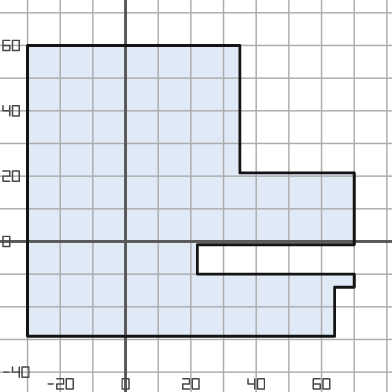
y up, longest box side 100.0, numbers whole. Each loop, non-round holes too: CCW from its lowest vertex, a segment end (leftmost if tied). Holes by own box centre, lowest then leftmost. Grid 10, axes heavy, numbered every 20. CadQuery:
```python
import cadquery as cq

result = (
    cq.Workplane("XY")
    .moveTo(-30.0, -29.0)
    .lineTo(64.0, -29.0)
    .lineTo(64.0, -14.0)
    .lineTo(70.0, -14.0)
    .lineTo(70.0, -10.0)
    .lineTo(22.0, -10.0)
    .lineTo(22.0, -1.0)
    .lineTo(70.0, -1.0)
    .lineTo(70.0, 21.0)
    .lineTo(35.0, 21.0)
    .lineTo(35.0, 60.0)
    .lineTo(-30.0, 60.0)
    .close()
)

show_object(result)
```